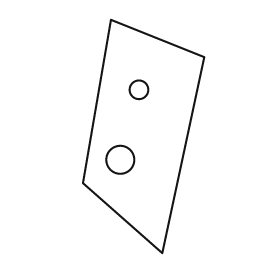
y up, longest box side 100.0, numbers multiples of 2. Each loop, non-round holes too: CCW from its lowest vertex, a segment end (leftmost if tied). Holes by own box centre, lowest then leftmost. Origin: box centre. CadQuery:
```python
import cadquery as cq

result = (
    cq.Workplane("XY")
    .moveTo(8.0, -50.0)
    .lineTo(26.0, 34.0)
    .lineTo(-14.0, 50.0)
    .lineTo(-26.0, -20.0)
    .close()
    .moveTo(-10.0, -10.0)
    .circle(6.0)
    .moveTo(-2.0, 20.0)
    .circle(4.0)
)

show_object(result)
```